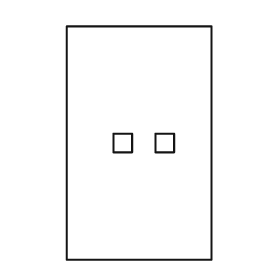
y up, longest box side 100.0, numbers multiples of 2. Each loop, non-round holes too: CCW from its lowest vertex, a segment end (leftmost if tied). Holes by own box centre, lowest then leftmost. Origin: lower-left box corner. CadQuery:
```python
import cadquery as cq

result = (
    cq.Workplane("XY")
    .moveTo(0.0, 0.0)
    .lineTo(62.0, 0.0)
    .lineTo(62.0, 100.0)
    .lineTo(0.0, 100.0)
    .close()
    .moveTo(20.0, 46.0)
    .lineTo(28.0, 46.0)
    .lineTo(28.0, 54.0)
    .lineTo(20.0, 54.0)
    .close()
    .moveTo(38.0, 46.0)
    .lineTo(46.0, 46.0)
    .lineTo(46.0, 54.0)
    .lineTo(38.0, 54.0)
    .close()
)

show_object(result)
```